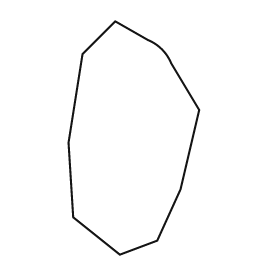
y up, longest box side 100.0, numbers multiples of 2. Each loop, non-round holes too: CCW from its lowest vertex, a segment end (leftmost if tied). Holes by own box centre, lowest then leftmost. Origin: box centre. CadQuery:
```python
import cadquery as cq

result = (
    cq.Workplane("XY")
    .moveTo(-6.0, -50.0)
    .lineTo(10.0, -44.0)
    .lineTo(20.0, -22.0)
    .lineTo(28.0, 12.0)
    .lineTo(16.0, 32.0)
    .threePointArc((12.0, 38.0), (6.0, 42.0))
    .lineTo(-8.0, 50.0)
    .lineTo(-22.0, 36.0)
    .lineTo(-28.0, -2.0)
    .lineTo(-26.0, -34.0)
    .close()
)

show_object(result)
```